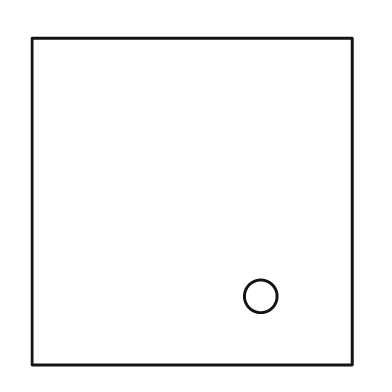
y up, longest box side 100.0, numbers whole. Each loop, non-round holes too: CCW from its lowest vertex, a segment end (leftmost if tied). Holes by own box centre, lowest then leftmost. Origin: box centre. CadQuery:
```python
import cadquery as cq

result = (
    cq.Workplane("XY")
    .moveTo(-49.0, -50.0)
    .lineTo(49.0, -50.0)
    .lineTo(49.0, 50.0)
    .lineTo(-49.0, 50.0)
    .close()
    .moveTo(21.0, -29.0)
    .circle(5.0)
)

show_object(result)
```